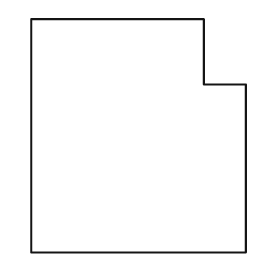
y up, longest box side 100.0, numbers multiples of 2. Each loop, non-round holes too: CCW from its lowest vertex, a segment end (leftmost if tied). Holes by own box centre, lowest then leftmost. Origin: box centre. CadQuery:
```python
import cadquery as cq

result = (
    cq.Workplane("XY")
    .moveTo(-46.0, -50.0)
    .lineTo(46.0, -50.0)
    .lineTo(46.0, 22.0)
    .lineTo(28.0, 22.0)
    .lineTo(28.0, 50.0)
    .lineTo(-46.0, 50.0)
    .close()
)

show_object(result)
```